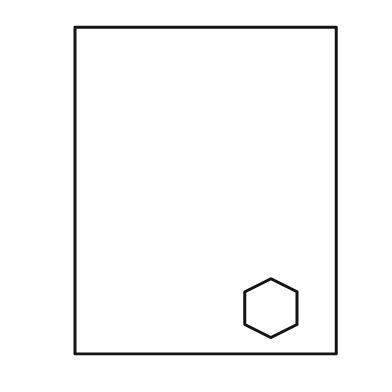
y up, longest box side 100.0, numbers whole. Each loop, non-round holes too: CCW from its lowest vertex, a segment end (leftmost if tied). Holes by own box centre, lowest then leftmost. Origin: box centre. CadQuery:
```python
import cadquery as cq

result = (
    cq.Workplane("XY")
    .moveTo(-40.0, -50.0)
    .lineTo(40.0, -50.0)
    .lineTo(40.0, 50.0)
    .lineTo(-40.0, 50.0)
    .close()
    .moveTo(20.0, -45.0)
    .lineTo(28.0, -41.0)
    .lineTo(28.0, -31.0)
    .lineTo(20.0, -27.0)
    .lineTo(12.0, -31.0)
    .lineTo(12.0, -41.0)
    .close()
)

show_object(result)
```